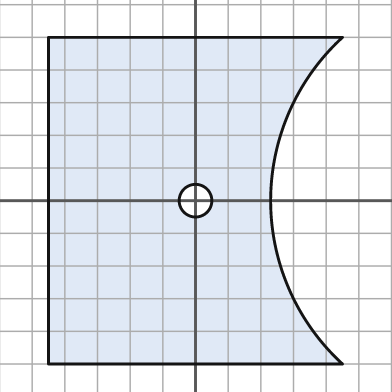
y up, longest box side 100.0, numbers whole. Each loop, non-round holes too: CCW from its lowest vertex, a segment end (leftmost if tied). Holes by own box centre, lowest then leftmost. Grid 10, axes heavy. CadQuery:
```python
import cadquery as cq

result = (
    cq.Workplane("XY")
    .moveTo(-45.0, -50.0)
    .lineTo(45.0, -50.0)
    .threePointArc((23.0, 0.0), (45.0, 50.0))
    .lineTo(-45.0, 50.0)
    .close()
    .moveTo(0.0, 0.0)
    .circle(5.0)
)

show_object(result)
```